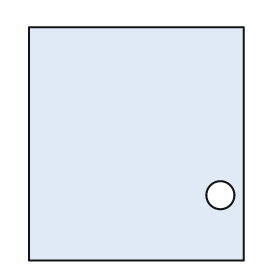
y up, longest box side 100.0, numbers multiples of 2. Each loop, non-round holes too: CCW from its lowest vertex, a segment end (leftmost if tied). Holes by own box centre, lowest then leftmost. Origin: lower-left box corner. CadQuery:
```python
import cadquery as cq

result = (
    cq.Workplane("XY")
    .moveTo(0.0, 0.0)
    .lineTo(92.0, 0.0)
    .lineTo(92.0, 100.0)
    .lineTo(0.0, 100.0)
    .close()
    .moveTo(82.0, 28.0)
    .circle(6.0)
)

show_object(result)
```